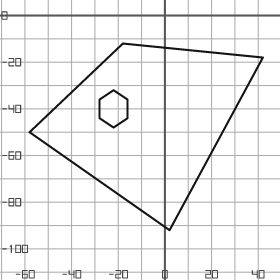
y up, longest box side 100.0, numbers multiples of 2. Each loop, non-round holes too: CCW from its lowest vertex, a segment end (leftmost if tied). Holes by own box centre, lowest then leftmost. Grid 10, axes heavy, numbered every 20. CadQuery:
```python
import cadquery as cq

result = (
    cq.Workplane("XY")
    .moveTo(2.0, -92.0)
    .lineTo(42.0, -18.0)
    .lineTo(-18.0, -12.0)
    .lineTo(-58.0, -50.0)
    .close()
    .moveTo(-22.0, -48.0)
    .lineTo(-16.0, -44.0)
    .lineTo(-16.0, -36.0)
    .lineTo(-22.0, -32.0)
    .lineTo(-28.0, -36.0)
    .lineTo(-28.0, -44.0)
    .close()
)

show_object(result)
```